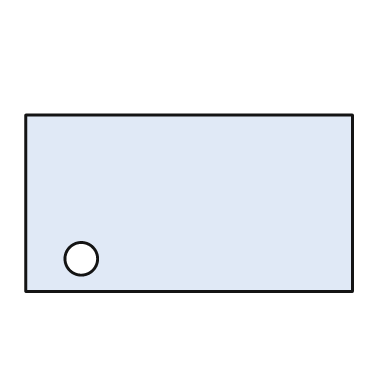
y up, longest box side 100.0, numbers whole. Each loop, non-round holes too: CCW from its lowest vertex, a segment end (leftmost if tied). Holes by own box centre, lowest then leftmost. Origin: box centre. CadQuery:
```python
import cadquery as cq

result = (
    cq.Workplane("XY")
    .moveTo(-50.0, -27.0)
    .lineTo(50.0, -27.0)
    .lineTo(50.0, 27.0)
    .lineTo(-50.0, 27.0)
    .close()
    .moveTo(-33.0, -17.0)
    .circle(5.0)
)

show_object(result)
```